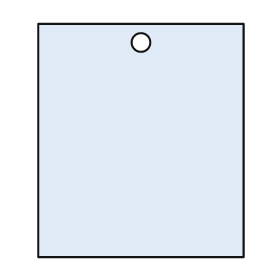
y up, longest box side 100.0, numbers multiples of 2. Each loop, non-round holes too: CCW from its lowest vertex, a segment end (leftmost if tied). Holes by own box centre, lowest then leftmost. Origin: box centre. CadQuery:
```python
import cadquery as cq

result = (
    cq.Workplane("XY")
    .moveTo(-44.0, -50.0)
    .lineTo(44.0, -50.0)
    .lineTo(44.0, 50.0)
    .lineTo(-44.0, 50.0)
    .close()
    .moveTo(0.0, 42.0)
    .circle(4.0)
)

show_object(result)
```